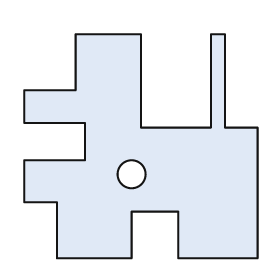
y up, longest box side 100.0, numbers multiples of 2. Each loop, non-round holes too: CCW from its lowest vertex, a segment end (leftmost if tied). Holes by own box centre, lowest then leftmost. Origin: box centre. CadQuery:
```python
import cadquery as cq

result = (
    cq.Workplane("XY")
    .moveTo(-36.0, -48.0)
    .lineTo(-4.0, -48.0)
    .lineTo(-4.0, -28.0)
    .lineTo(16.0, -28.0)
    .lineTo(16.0, -48.0)
    .lineTo(50.0, -48.0)
    .lineTo(50.0, 8.0)
    .lineTo(36.0, 8.0)
    .lineTo(36.0, 48.0)
    .lineTo(30.0, 48.0)
    .lineTo(30.0, 8.0)
    .lineTo(0.0, 8.0)
    .lineTo(0.0, 48.0)
    .lineTo(-28.0, 48.0)
    .lineTo(-28.0, 24.0)
    .lineTo(-50.0, 24.0)
    .lineTo(-50.0, 10.0)
    .lineTo(-24.0, 10.0)
    .lineTo(-24.0, -6.0)
    .lineTo(-50.0, -6.0)
    .lineTo(-50.0, -24.0)
    .lineTo(-36.0, -24.0)
    .close()
    .moveTo(-4.0, -12.0)
    .circle(6.0)
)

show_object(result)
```